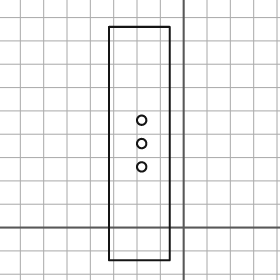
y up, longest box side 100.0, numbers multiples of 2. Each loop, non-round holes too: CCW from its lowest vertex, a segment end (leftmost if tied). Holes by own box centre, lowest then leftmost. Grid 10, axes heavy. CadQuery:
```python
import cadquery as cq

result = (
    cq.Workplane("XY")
    .moveTo(-32.0, -14.0)
    .lineTo(-6.0, -14.0)
    .lineTo(-6.0, 86.0)
    .lineTo(-32.0, 86.0)
    .close()
    .moveTo(-18.0, 26.0)
    .circle(2.0)
    .moveTo(-18.0, 36.0)
    .circle(2.0)
    .moveTo(-18.0, 46.0)
    .circle(2.0)
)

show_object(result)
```